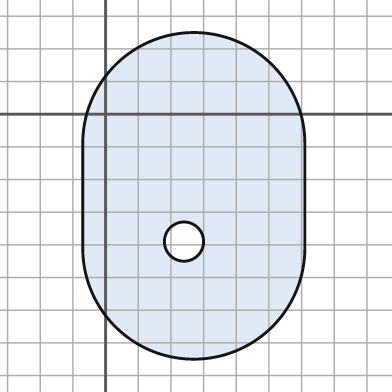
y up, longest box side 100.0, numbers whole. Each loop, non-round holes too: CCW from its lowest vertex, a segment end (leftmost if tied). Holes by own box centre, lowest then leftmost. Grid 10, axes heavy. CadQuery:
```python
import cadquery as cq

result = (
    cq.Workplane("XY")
    .moveTo(-7.0, -41.0)
    .threePointArc((27.0, -75.0), (61.0, -41.0))
    .lineTo(61.0, -9.0)
    .threePointArc((27.0, 25.0), (-7.0, -9.0))
    .close()
    .moveTo(24.0, -39.0)
    .circle(6.0)
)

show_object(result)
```